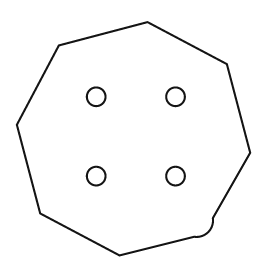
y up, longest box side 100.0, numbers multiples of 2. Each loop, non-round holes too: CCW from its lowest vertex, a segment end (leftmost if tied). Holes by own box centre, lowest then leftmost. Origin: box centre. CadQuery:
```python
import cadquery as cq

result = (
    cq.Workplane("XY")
    .moveTo(-6.0, -50.0)
    .lineTo(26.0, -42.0)
    .threePointArc((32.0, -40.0), (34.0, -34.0))
    .lineTo(50.0, -6.0)
    .lineTo(40.0, 32.0)
    .lineTo(6.0, 50.0)
    .lineTo(-32.0, 40.0)
    .lineTo(-50.0, 6.0)
    .lineTo(-40.0, -32.0)
    .close()
    .moveTo(-16.0, -16.0)
    .circle(4.0)
    .moveTo(18.0, -16.0)
    .circle(4.0)
    .moveTo(-16.0, 18.0)
    .circle(4.0)
    .moveTo(18.0, 18.0)
    .circle(4.0)
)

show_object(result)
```